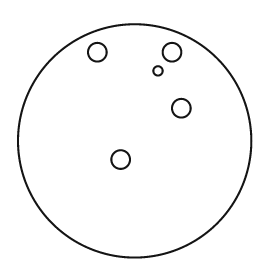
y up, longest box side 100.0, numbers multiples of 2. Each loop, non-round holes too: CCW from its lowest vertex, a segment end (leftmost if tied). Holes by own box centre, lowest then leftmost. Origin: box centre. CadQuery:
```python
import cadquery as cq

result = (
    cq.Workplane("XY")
    .moveTo(0.0, 0.0)
    .circle(50.0)
    .moveTo(-6.0, -8.0)
    .circle(4.0)
    .moveTo(20.0, 14.0)
    .circle(4.0)
    .moveTo(10.0, 30.0)
    .circle(2.0)
    .moveTo(-16.0, 38.0)
    .circle(4.0)
    .moveTo(16.0, 38.0)
    .circle(4.0)
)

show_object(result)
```